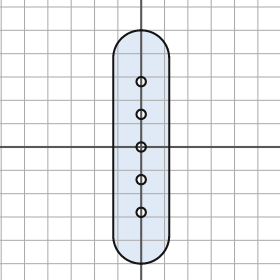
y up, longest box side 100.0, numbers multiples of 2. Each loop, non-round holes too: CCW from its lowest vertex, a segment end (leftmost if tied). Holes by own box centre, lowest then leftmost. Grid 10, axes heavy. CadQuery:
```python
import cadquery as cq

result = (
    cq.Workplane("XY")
    .moveTo(-12.0, -38.0)
    .threePointArc((0.0, -50.0), (12.0, -38.0))
    .lineTo(12.0, 38.0)
    .threePointArc((0.0, 50.0), (-12.0, 38.0))
    .close()
    .moveTo(0.0, -28.0)
    .circle(2.0)
    .moveTo(0.0, -14.0)
    .circle(2.0)
    .moveTo(0.0, 0.0)
    .circle(2.0)
    .moveTo(0.0, 14.0)
    .circle(2.0)
    .moveTo(0.0, 28.0)
    .circle(2.0)
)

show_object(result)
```